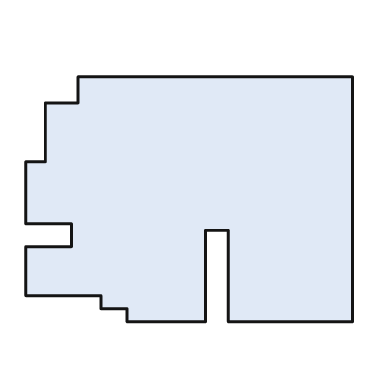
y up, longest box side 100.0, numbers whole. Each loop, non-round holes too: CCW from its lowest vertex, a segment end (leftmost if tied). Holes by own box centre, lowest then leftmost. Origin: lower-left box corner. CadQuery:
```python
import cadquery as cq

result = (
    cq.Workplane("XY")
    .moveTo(31.0, 0.0)
    .lineTo(55.0, 0.0)
    .lineTo(55.0, 28.0)
    .lineTo(62.0, 28.0)
    .lineTo(62.0, 0.0)
    .lineTo(100.0, 0.0)
    .lineTo(100.0, 75.0)
    .lineTo(16.0, 75.0)
    .lineTo(16.0, 67.0)
    .lineTo(6.0, 67.0)
    .lineTo(6.0, 49.0)
    .lineTo(0.0, 49.0)
    .lineTo(0.0, 30.0)
    .lineTo(14.0, 30.0)
    .lineTo(14.0, 23.0)
    .lineTo(0.0, 23.0)
    .lineTo(0.0, 8.0)
    .lineTo(23.0, 8.0)
    .lineTo(23.0, 4.0)
    .lineTo(31.0, 4.0)
    .close()
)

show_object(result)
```